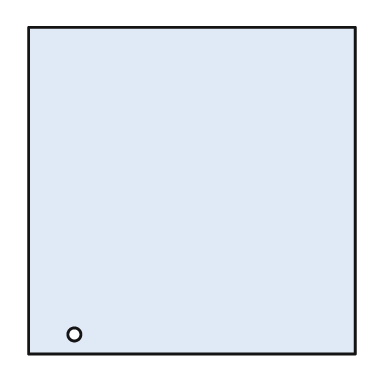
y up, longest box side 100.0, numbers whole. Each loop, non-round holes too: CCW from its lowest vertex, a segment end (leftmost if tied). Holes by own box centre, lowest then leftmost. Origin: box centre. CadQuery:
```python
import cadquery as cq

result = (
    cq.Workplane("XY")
    .moveTo(-50.0, -50.0)
    .lineTo(50.0, -50.0)
    .lineTo(50.0, 50.0)
    .lineTo(-50.0, 50.0)
    .close()
    .moveTo(-36.0, -44.0)
    .circle(2.0)
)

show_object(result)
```